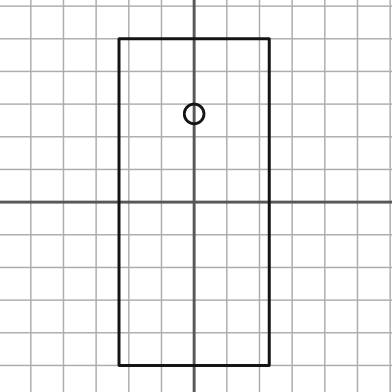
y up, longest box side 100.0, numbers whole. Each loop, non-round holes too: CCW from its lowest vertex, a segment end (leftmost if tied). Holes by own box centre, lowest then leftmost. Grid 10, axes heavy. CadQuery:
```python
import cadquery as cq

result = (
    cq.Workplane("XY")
    .moveTo(-23.0, -50.0)
    .lineTo(23.0, -50.0)
    .lineTo(23.0, 50.0)
    .lineTo(-23.0, 50.0)
    .close()
    .moveTo(0.0, 27.0)
    .circle(3.0)
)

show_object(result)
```